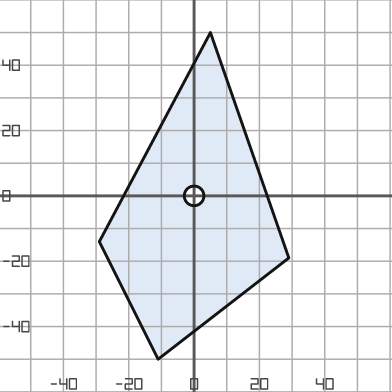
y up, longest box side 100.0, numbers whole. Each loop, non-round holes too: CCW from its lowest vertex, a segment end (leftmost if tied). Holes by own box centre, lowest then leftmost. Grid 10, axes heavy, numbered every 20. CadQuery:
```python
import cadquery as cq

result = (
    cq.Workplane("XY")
    .moveTo(-11.0, -50.0)
    .lineTo(29.0, -19.0)
    .lineTo(5.0, 50.0)
    .lineTo(-29.0, -14.0)
    .close()
    .moveTo(0.0, 0.0)
    .circle(3.0)
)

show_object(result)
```